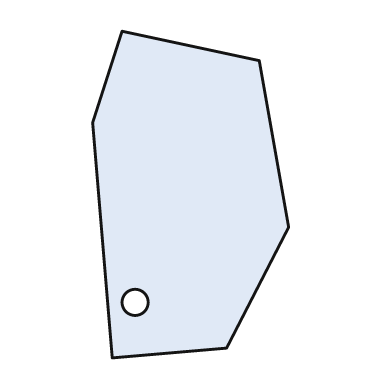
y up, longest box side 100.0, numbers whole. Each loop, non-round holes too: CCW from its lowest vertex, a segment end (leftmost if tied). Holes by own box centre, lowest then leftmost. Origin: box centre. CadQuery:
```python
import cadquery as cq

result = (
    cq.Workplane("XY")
    .moveTo(-24.0, -50.0)
    .lineTo(11.0, -47.0)
    .lineTo(30.0, -10.0)
    .lineTo(21.0, 41.0)
    .lineTo(-21.0, 50.0)
    .lineTo(-30.0, 22.0)
    .close()
    .moveTo(-17.0, -33.0)
    .circle(4.0)
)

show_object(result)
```